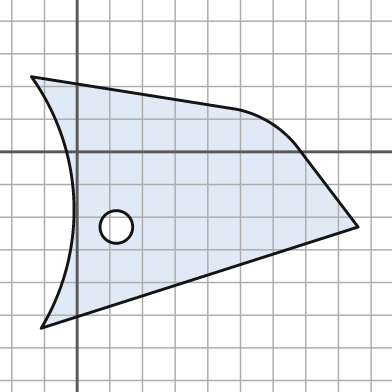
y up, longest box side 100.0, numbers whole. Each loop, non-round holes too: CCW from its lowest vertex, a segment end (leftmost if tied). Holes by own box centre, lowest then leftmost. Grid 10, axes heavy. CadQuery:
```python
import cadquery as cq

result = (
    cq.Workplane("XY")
    .moveTo(-11.0, -54.0)
    .lineTo(86.0, -23.0)
    .lineTo(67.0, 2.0)
    .threePointArc((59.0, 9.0), (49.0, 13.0))
    .lineTo(-14.0, 23.0)
    .threePointArc((-1.0, -15.0), (-11.0, -54.0))
    .close()
    .moveTo(12.0, -23.0)
    .circle(5.0)
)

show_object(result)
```